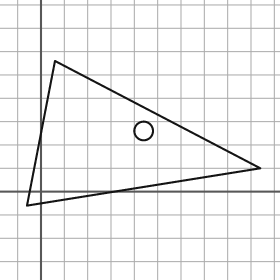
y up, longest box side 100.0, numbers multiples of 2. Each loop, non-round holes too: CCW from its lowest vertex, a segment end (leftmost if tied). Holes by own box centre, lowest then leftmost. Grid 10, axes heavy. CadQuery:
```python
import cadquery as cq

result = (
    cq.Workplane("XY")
    .moveTo(-6.0, -6.0)
    .lineTo(94.0, 10.0)
    .lineTo(6.0, 56.0)
    .close()
    .moveTo(44.0, 26.0)
    .circle(4.0)
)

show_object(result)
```